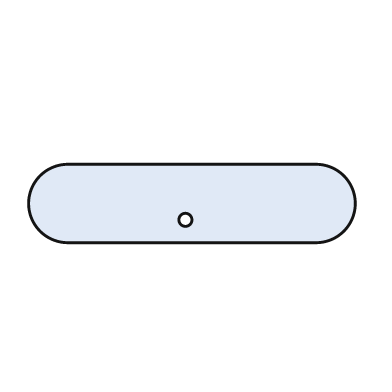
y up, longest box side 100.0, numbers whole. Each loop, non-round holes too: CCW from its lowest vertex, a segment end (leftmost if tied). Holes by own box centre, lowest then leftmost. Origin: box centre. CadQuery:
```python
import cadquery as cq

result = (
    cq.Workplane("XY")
    .moveTo(-38.0, -12.0)
    .lineTo(38.0, -12.0)
    .threePointArc((50.0, 0.0), (38.0, 12.0))
    .lineTo(-38.0, 12.0)
    .threePointArc((-50.0, 0.0), (-38.0, -12.0))
    .close()
    .moveTo(-2.0, -5.0)
    .circle(2.0)
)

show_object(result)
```